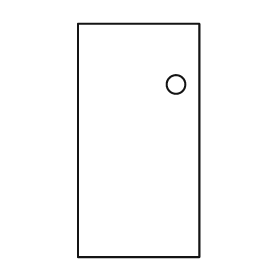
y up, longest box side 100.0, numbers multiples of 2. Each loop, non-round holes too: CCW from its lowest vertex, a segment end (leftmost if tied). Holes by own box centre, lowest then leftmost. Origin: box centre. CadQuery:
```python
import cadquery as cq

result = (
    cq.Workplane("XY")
    .moveTo(-26.0, -50.0)
    .lineTo(26.0, -50.0)
    .lineTo(26.0, 50.0)
    .lineTo(-26.0, 50.0)
    .close()
    .moveTo(16.0, 24.0)
    .circle(4.0)
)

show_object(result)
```